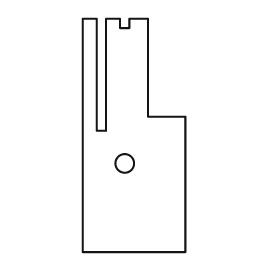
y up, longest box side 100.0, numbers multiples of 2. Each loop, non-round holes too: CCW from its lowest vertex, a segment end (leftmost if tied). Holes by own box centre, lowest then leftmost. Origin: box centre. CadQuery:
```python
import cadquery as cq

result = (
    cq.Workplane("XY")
    .moveTo(-22.0, -50.0)
    .lineTo(22.0, -50.0)
    .lineTo(22.0, 8.0)
    .lineTo(6.0, 8.0)
    .lineTo(6.0, 50.0)
    .lineTo(-2.0, 50.0)
    .lineTo(-2.0, 46.0)
    .lineTo(-6.0, 46.0)
    .lineTo(-6.0, 50.0)
    .lineTo(-12.0, 50.0)
    .lineTo(-12.0, 2.0)
    .lineTo(-16.0, 2.0)
    .lineTo(-16.0, 50.0)
    .lineTo(-22.0, 50.0)
    .close()
    .moveTo(-4.0, -12.0)
    .circle(4.0)
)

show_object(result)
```